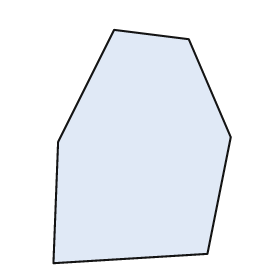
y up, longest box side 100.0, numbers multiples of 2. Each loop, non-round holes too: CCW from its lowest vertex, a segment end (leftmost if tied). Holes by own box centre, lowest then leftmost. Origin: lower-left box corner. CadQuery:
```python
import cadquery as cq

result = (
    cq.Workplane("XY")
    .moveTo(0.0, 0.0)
    .lineTo(66.0, 4.0)
    .lineTo(76.0, 54.0)
    .lineTo(58.0, 96.0)
    .lineTo(26.0, 100.0)
    .lineTo(2.0, 52.0)
    .close()
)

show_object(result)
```